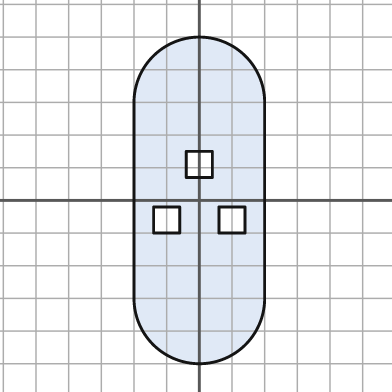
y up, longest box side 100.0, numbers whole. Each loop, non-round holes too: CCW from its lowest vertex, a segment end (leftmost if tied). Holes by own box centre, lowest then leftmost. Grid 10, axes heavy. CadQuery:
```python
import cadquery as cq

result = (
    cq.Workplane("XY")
    .moveTo(-20.0, -30.0)
    .threePointArc((0.0, -50.0), (20.0, -30.0))
    .lineTo(20.0, 30.0)
    .threePointArc((0.0, 50.0), (-20.0, 30.0))
    .close()
    .moveTo(-14.0, -10.0)
    .lineTo(-6.0, -10.0)
    .lineTo(-6.0, -2.0)
    .lineTo(-14.0, -2.0)
    .close()
    .moveTo(6.0, -10.0)
    .lineTo(14.0, -10.0)
    .lineTo(14.0, -2.0)
    .lineTo(6.0, -2.0)
    .close()
    .moveTo(-4.0, 7.0)
    .lineTo(4.0, 7.0)
    .lineTo(4.0, 15.0)
    .lineTo(-4.0, 15.0)
    .close()
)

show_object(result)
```